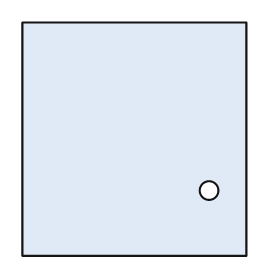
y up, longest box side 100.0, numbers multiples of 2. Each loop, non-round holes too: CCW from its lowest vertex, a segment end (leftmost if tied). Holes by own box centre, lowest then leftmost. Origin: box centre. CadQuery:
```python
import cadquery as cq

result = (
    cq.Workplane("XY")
    .moveTo(-48.0, -50.0)
    .lineTo(48.0, -50.0)
    .lineTo(48.0, 50.0)
    .lineTo(-48.0, 50.0)
    .close()
    .moveTo(32.0, -22.0)
    .circle(4.0)
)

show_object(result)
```